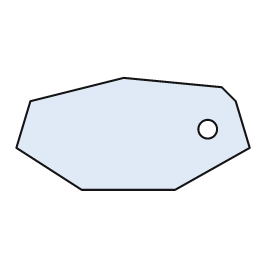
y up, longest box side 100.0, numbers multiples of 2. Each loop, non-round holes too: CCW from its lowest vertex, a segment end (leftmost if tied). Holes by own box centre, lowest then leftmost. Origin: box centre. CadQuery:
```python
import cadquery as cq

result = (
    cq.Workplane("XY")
    .moveTo(-22.0, -24.0)
    .lineTo(18.0, -24.0)
    .lineTo(50.0, -6.0)
    .lineTo(44.0, 14.0)
    .lineTo(38.0, 20.0)
    .lineTo(-4.0, 24.0)
    .lineTo(-44.0, 14.0)
    .lineTo(-50.0, -6.0)
    .close()
    .moveTo(32.0, 2.0)
    .circle(4.0)
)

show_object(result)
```